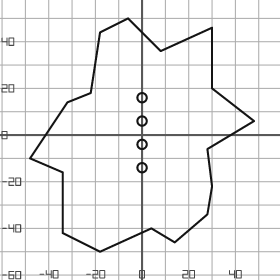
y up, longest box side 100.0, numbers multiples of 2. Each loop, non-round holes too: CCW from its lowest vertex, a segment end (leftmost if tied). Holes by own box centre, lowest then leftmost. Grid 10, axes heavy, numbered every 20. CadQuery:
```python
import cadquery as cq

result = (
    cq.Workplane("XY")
    .moveTo(-18.0, -50.0)
    .lineTo(4.0, -40.0)
    .lineTo(14.0, -46.0)
    .lineTo(28.0, -34.0)
    .lineTo(30.0, -22.0)
    .lineTo(28.0, -6.0)
    .lineTo(48.0, 6.0)
    .lineTo(30.0, 20.0)
    .lineTo(30.0, 46.0)
    .lineTo(8.0, 36.0)
    .lineTo(-6.0, 50.0)
    .lineTo(-18.0, 44.0)
    .lineTo(-22.0, 18.0)
    .lineTo(-32.0, 14.0)
    .lineTo(-48.0, -10.0)
    .lineTo(-34.0, -16.0)
    .lineTo(-34.0, -42.0)
    .close()
    .moveTo(0.0, -14.0)
    .circle(2.0)
    .moveTo(0.0, -4.0)
    .circle(2.0)
    .moveTo(0.0, 6.0)
    .circle(2.0)
    .moveTo(0.0, 16.0)
    .circle(2.0)
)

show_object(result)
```